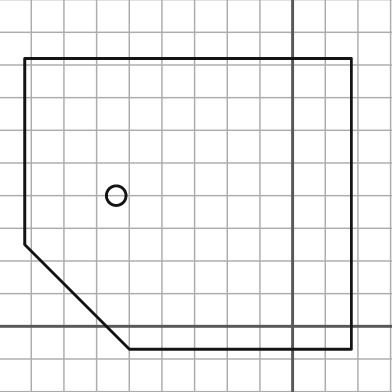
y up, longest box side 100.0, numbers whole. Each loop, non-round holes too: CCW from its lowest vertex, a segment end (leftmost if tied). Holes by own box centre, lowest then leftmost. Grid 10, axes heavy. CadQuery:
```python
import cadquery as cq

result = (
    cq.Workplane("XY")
    .moveTo(-50.0, -7.0)
    .lineTo(18.0, -7.0)
    .lineTo(18.0, 82.0)
    .lineTo(-82.0, 82.0)
    .lineTo(-82.0, 25.0)
    .close()
    .moveTo(-54.0, 40.0)
    .circle(3.0)
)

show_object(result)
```